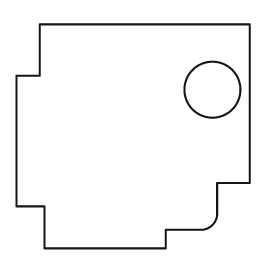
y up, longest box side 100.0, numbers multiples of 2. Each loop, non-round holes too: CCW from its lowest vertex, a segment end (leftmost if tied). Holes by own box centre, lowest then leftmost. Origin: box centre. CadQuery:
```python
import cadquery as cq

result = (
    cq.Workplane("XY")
    .moveTo(-38.0, -48.0)
    .lineTo(14.0, -48.0)
    .lineTo(14.0, -40.0)
    .lineTo(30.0, -40.0)
    .threePointArc((34.0, -38.0), (36.0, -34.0))
    .lineTo(36.0, -20.0)
    .lineTo(50.0, -20.0)
    .lineTo(50.0, 48.0)
    .lineTo(-40.0, 48.0)
    .lineTo(-40.0, 26.0)
    .lineTo(-50.0, 26.0)
    .lineTo(-50.0, -30.0)
    .lineTo(-38.0, -30.0)
    .close()
    .moveTo(34.0, 20.0)
    .circle(12.0)
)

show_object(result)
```